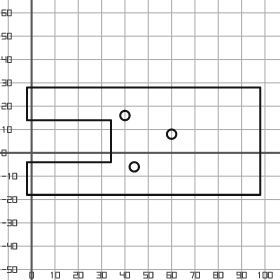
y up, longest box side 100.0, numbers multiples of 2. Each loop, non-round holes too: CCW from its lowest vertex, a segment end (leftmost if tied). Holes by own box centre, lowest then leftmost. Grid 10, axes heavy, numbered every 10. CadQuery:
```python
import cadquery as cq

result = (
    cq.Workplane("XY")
    .moveTo(-2.0, -18.0)
    .lineTo(98.0, -18.0)
    .lineTo(98.0, 28.0)
    .lineTo(-2.0, 28.0)
    .lineTo(-2.0, 14.0)
    .lineTo(34.0, 14.0)
    .lineTo(34.0, -4.0)
    .lineTo(-2.0, -4.0)
    .close()
    .moveTo(44.0, -6.0)
    .circle(2.0)
    .moveTo(60.0, 8.0)
    .circle(2.0)
    .moveTo(40.0, 16.0)
    .circle(2.0)
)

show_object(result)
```